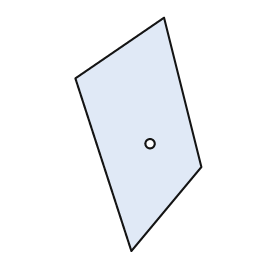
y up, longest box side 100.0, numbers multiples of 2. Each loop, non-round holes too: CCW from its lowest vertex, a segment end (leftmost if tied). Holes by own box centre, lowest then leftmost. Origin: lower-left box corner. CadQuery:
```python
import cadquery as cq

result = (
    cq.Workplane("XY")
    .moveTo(24.0, 0.0)
    .lineTo(54.0, 36.0)
    .lineTo(38.0, 100.0)
    .lineTo(0.0, 74.0)
    .close()
    .moveTo(32.0, 46.0)
    .circle(2.0)
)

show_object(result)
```